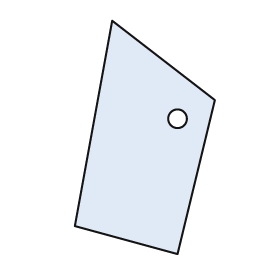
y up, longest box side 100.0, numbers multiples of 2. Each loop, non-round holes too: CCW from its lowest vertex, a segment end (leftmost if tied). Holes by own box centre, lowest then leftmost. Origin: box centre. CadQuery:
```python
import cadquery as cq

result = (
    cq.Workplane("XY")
    .moveTo(14.0, -50.0)
    .lineTo(30.0, 16.0)
    .lineTo(-14.0, 50.0)
    .lineTo(-30.0, -38.0)
    .close()
    .moveTo(14.0, 8.0)
    .circle(4.0)
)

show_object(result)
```